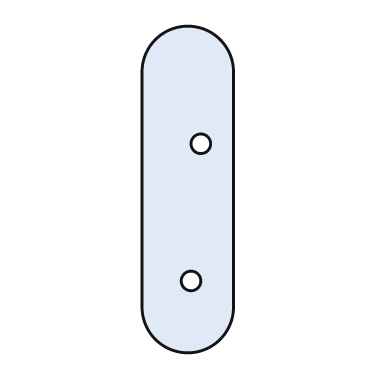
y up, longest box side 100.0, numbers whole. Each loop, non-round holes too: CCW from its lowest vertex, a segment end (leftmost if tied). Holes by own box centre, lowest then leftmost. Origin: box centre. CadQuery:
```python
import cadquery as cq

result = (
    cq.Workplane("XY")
    .moveTo(-14.0, -36.0)
    .threePointArc((0.0, -50.0), (14.0, -36.0))
    .lineTo(14.0, 36.0)
    .threePointArc((0.0, 50.0), (-14.0, 36.0))
    .close()
    .moveTo(1.0, -28.0)
    .circle(3.0)
    .moveTo(4.0, 14.0)
    .circle(3.0)
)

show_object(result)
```